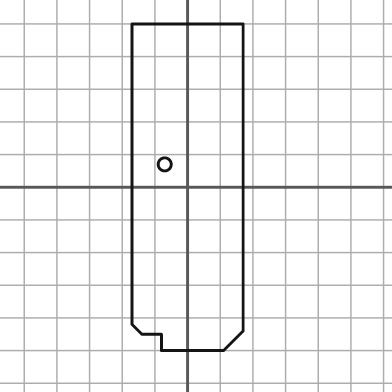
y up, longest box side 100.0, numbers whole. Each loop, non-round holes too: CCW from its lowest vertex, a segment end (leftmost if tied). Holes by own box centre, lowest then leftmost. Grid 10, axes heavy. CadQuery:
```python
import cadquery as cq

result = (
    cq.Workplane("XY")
    .moveTo(-8.0, -50.0)
    .lineTo(11.0, -50.0)
    .lineTo(17.0, -44.0)
    .lineTo(17.0, 50.0)
    .lineTo(-17.0, 50.0)
    .lineTo(-17.0, -42.0)
    .lineTo(-14.0, -45.0)
    .lineTo(-8.0, -45.0)
    .close()
    .moveTo(-7.0, 7.0)
    .circle(2.0)
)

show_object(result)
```